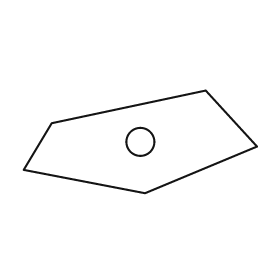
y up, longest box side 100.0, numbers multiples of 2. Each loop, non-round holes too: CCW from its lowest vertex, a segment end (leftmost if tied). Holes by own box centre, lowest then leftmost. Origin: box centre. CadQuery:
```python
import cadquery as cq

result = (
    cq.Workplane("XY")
    .moveTo(2.0, -22.0)
    .lineTo(50.0, -2.0)
    .lineTo(28.0, 22.0)
    .lineTo(-38.0, 8.0)
    .lineTo(-50.0, -12.0)
    .close()
    .moveTo(0.0, 0.0)
    .circle(6.0)
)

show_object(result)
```